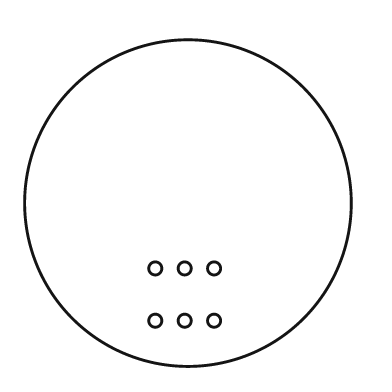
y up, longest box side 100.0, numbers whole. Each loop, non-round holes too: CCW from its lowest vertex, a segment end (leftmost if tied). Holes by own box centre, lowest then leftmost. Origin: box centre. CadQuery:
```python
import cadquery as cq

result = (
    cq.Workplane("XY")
    .moveTo(0.0, 0.0)
    .circle(50.0)
    .moveTo(-10.0, -36.0)
    .circle(2.0)
    .moveTo(-1.0, -36.0)
    .circle(2.0)
    .moveTo(8.0, -36.0)
    .circle(2.0)
    .moveTo(-10.0, -20.0)
    .circle(2.0)
    .moveTo(-1.0, -20.0)
    .circle(2.0)
    .moveTo(8.0, -20.0)
    .circle(2.0)
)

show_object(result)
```